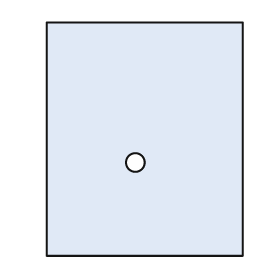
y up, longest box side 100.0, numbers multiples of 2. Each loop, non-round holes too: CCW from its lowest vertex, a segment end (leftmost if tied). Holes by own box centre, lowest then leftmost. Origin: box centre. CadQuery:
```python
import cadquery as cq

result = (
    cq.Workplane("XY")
    .moveTo(-42.0, -50.0)
    .lineTo(42.0, -50.0)
    .lineTo(42.0, 50.0)
    .lineTo(-42.0, 50.0)
    .close()
    .moveTo(-4.0, -10.0)
    .circle(4.0)
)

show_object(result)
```